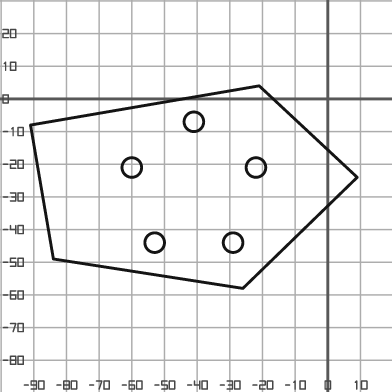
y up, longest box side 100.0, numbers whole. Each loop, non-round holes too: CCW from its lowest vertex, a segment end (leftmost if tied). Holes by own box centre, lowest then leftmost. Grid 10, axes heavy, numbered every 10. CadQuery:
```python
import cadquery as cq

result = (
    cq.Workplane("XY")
    .moveTo(-26.0, -58.0)
    .lineTo(9.0, -24.0)
    .lineTo(-21.0, 4.0)
    .lineTo(-91.0, -8.0)
    .lineTo(-84.0, -49.0)
    .close()
    .moveTo(-53.0, -44.0)
    .circle(3.0)
    .moveTo(-29.0, -44.0)
    .circle(3.0)
    .moveTo(-60.0, -21.0)
    .circle(3.0)
    .moveTo(-22.0, -21.0)
    .circle(3.0)
    .moveTo(-41.0, -7.0)
    .circle(3.0)
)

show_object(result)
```